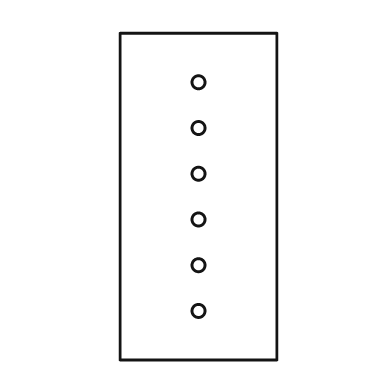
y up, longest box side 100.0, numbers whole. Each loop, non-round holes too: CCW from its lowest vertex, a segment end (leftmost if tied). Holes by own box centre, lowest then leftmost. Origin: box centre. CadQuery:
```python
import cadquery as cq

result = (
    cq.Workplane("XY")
    .moveTo(-24.0, -50.0)
    .lineTo(24.0, -50.0)
    .lineTo(24.0, 50.0)
    .lineTo(-24.0, 50.0)
    .close()
    .moveTo(0.0, -35.0)
    .circle(2.0)
    .moveTo(0.0, -21.0)
    .circle(2.0)
    .moveTo(0.0, -7.0)
    .circle(2.0)
    .moveTo(0.0, 7.0)
    .circle(2.0)
    .moveTo(0.0, 21.0)
    .circle(2.0)
    .moveTo(0.0, 35.0)
    .circle(2.0)
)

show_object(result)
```